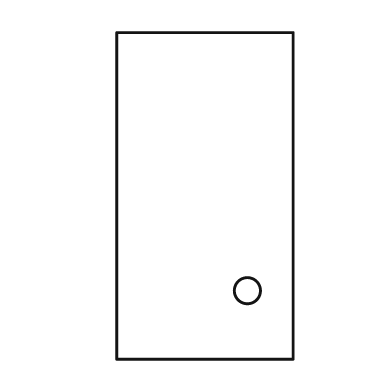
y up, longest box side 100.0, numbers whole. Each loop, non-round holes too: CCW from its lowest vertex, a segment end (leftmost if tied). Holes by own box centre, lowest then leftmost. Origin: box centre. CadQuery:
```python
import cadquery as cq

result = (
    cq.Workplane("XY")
    .moveTo(-27.0, -50.0)
    .lineTo(27.0, -50.0)
    .lineTo(27.0, 50.0)
    .lineTo(-27.0, 50.0)
    .close()
    .moveTo(13.0, -29.0)
    .circle(4.0)
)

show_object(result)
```